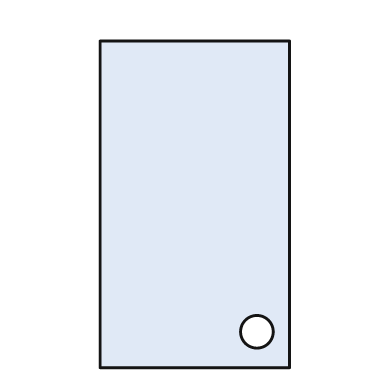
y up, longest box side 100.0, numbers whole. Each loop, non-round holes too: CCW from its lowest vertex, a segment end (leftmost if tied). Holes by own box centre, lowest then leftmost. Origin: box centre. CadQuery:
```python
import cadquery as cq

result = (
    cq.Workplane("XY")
    .moveTo(-29.0, -50.0)
    .lineTo(29.0, -50.0)
    .lineTo(29.0, 50.0)
    .lineTo(-29.0, 50.0)
    .close()
    .moveTo(19.0, -39.0)
    .circle(5.0)
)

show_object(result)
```